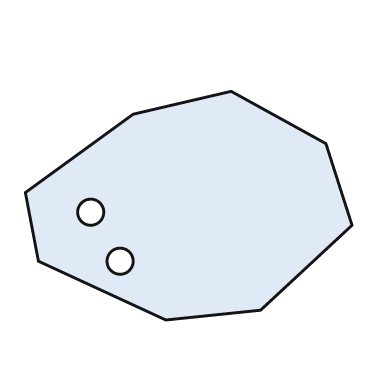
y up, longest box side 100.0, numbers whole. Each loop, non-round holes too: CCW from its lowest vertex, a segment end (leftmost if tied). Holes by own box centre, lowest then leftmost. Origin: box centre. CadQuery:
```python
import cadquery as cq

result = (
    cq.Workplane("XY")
    .moveTo(-7.0, -35.0)
    .lineTo(22.0, -32.0)
    .lineTo(50.0, -6.0)
    .lineTo(42.0, 19.0)
    .lineTo(13.0, 35.0)
    .lineTo(-17.0, 28.0)
    .lineTo(-50.0, 4.0)
    .lineTo(-46.0, -17.0)
    .close()
    .moveTo(-21.0, -17.0)
    .circle(4.0)
    .moveTo(-30.0, -2.0)
    .circle(4.0)
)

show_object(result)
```